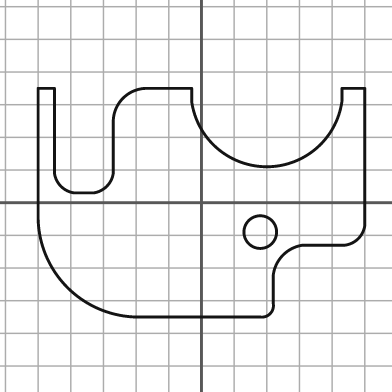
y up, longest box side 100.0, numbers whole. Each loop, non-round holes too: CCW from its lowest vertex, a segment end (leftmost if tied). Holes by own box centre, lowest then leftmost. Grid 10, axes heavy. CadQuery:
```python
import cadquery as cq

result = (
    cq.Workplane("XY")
    .moveTo(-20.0, -35.0)
    .lineTo(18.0, -35.0)
    .threePointArc((21.0, -34.0), (22.0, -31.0))
    .lineTo(22.0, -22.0)
    .threePointArc((25.0, -16.0), (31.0, -13.0))
    .lineTo(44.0, -13.0)
    .threePointArc((48.0, -11.0), (50.0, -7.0))
    .lineTo(50.0, 35.0)
    .lineTo(43.0, 35.0)
    .lineTo(43.0, 31.0)
    .threePointArc((20.0, 11.0), (-3.0, 31.0))
    .lineTo(-3.0, 35.0)
    .lineTo(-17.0, 35.0)
    .threePointArc((-24.0, 32.0), (-27.0, 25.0))
    .lineTo(-27.0, 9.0)
    .threePointArc((-29.0, 5.0), (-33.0, 3.0))
    .lineTo(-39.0, 3.0)
    .threePointArc((-43.0, 5.0), (-45.0, 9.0))
    .lineTo(-45.0, 35.0)
    .lineTo(-50.0, 35.0)
    .lineTo(-50.0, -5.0)
    .threePointArc((-41.0, -26.0), (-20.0, -35.0))
    .close()
    .moveTo(18.0, -9.0)
    .circle(5.0)
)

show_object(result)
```